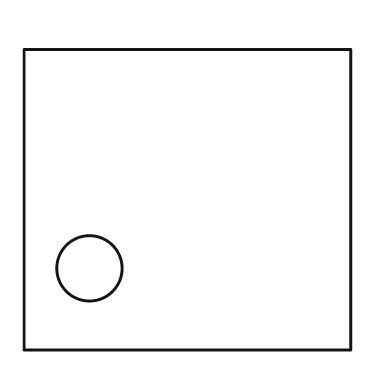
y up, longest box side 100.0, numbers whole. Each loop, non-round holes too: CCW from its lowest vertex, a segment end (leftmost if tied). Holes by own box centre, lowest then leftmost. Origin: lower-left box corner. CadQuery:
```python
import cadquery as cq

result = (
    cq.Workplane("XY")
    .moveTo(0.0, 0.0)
    .lineTo(100.0, 0.0)
    .lineTo(100.0, 92.0)
    .lineTo(0.0, 92.0)
    .close()
    .moveTo(20.0, 25.0)
    .circle(10.0)
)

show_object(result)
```